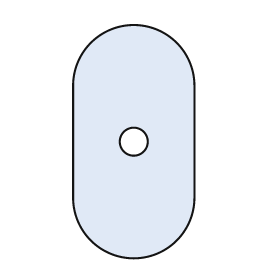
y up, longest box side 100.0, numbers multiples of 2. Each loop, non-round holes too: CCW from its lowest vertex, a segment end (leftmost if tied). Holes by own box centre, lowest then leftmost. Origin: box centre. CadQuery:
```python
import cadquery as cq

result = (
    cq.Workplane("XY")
    .moveTo(-26.0, -24.0)
    .threePointArc((0.0, -50.0), (26.0, -24.0))
    .lineTo(26.0, 24.0)
    .threePointArc((0.0, 50.0), (-26.0, 24.0))
    .close()
    .moveTo(0.0, 0.0)
    .circle(6.0)
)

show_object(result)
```